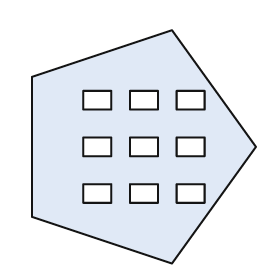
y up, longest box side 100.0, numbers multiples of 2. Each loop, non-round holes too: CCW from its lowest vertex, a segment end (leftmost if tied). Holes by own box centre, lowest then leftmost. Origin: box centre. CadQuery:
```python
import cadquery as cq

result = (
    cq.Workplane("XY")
    .moveTo(12.0, -50.0)
    .lineTo(48.0, 0.0)
    .lineTo(12.0, 50.0)
    .lineTo(-48.0, 30.0)
    .lineTo(-48.0, -30.0)
    .close()
    .moveTo(-26.0, -24.0)
    .lineTo(-14.0, -24.0)
    .lineTo(-14.0, -16.0)
    .lineTo(-26.0, -16.0)
    .close()
    .moveTo(-6.0, -24.0)
    .lineTo(6.0, -24.0)
    .lineTo(6.0, -16.0)
    .lineTo(-6.0, -16.0)
    .close()
    .moveTo(14.0, -24.0)
    .lineTo(26.0, -24.0)
    .lineTo(26.0, -16.0)
    .lineTo(14.0, -16.0)
    .close()
    .moveTo(-26.0, -4.0)
    .lineTo(-14.0, -4.0)
    .lineTo(-14.0, 4.0)
    .lineTo(-26.0, 4.0)
    .close()
    .moveTo(-6.0, -4.0)
    .lineTo(6.0, -4.0)
    .lineTo(6.0, 4.0)
    .lineTo(-6.0, 4.0)
    .close()
    .moveTo(14.0, -4.0)
    .lineTo(26.0, -4.0)
    .lineTo(26.0, 4.0)
    .lineTo(14.0, 4.0)
    .close()
    .moveTo(-26.0, 16.0)
    .lineTo(-14.0, 16.0)
    .lineTo(-14.0, 24.0)
    .lineTo(-26.0, 24.0)
    .close()
    .moveTo(-6.0, 16.0)
    .lineTo(6.0, 16.0)
    .lineTo(6.0, 24.0)
    .lineTo(-6.0, 24.0)
    .close()
    .moveTo(14.0, 16.0)
    .lineTo(26.0, 16.0)
    .lineTo(26.0, 24.0)
    .lineTo(14.0, 24.0)
    .close()
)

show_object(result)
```